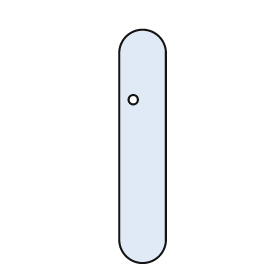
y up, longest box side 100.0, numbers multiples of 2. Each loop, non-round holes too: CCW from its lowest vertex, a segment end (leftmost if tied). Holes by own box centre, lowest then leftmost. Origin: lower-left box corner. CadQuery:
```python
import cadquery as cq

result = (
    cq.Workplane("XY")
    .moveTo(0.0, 10.0)
    .threePointArc((10.0, 0.0), (20.0, 10.0))
    .lineTo(20.0, 90.0)
    .threePointArc((10.0, 100.0), (0.0, 90.0))
    .close()
    .moveTo(6.0, 70.0)
    .circle(2.0)
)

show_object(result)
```